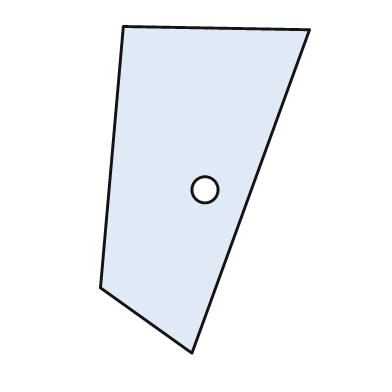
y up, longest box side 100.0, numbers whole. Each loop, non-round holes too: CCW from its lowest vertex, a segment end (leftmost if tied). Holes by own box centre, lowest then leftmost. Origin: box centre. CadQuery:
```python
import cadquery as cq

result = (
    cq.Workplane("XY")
    .moveTo(-4.0, -50.0)
    .lineTo(32.0, 49.0)
    .lineTo(-25.0, 50.0)
    .lineTo(-32.0, -30.0)
    .close()
    .moveTo(0.0, 0.0)
    .circle(4.0)
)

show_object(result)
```